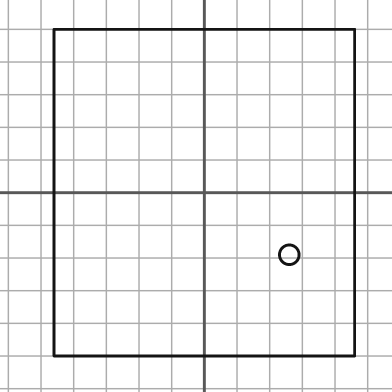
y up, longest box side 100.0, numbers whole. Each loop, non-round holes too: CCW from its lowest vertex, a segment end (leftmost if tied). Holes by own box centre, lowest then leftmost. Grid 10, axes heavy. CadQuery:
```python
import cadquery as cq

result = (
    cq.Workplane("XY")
    .moveTo(-46.0, -50.0)
    .lineTo(46.0, -50.0)
    .lineTo(46.0, 50.0)
    .lineTo(-46.0, 50.0)
    .close()
    .moveTo(26.0, -19.0)
    .circle(3.0)
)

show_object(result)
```